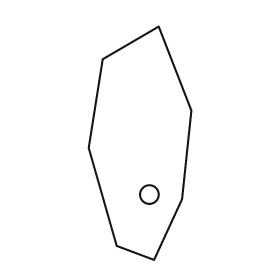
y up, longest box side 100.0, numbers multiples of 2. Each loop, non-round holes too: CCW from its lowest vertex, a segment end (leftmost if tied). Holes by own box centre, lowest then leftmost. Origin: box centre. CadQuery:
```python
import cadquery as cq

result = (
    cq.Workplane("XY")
    .moveTo(6.0, -50.0)
    .lineTo(18.0, -24.0)
    .lineTo(22.0, 14.0)
    .lineTo(8.0, 50.0)
    .lineTo(-16.0, 36.0)
    .lineTo(-22.0, -2.0)
    .lineTo(-10.0, -44.0)
    .close()
    .moveTo(4.0, -22.0)
    .circle(4.0)
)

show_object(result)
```